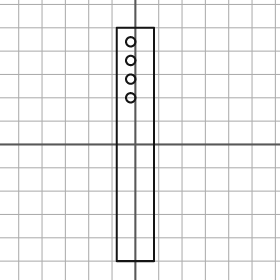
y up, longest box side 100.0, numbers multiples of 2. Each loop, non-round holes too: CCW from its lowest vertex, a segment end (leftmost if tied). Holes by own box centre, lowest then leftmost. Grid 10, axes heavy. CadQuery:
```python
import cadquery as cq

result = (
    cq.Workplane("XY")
    .moveTo(-8.0, -50.0)
    .lineTo(8.0, -50.0)
    .lineTo(8.0, 50.0)
    .lineTo(-8.0, 50.0)
    .close()
    .moveTo(-2.0, 20.0)
    .circle(2.0)
    .moveTo(-2.0, 28.0)
    .circle(2.0)
    .moveTo(-2.0, 36.0)
    .circle(2.0)
    .moveTo(-2.0, 44.0)
    .circle(2.0)
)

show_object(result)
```